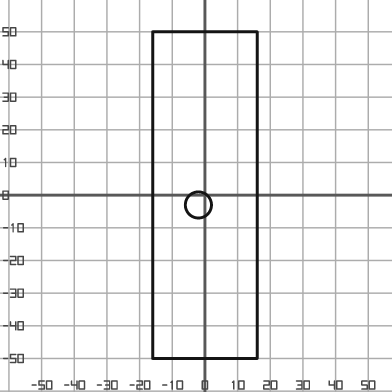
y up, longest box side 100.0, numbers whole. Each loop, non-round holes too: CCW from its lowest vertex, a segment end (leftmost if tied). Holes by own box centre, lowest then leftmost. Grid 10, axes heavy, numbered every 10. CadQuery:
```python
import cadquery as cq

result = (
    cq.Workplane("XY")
    .moveTo(-16.0, -50.0)
    .lineTo(16.0, -50.0)
    .lineTo(16.0, 50.0)
    .lineTo(-16.0, 50.0)
    .close()
    .moveTo(-2.0, -3.0)
    .circle(4.0)
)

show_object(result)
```